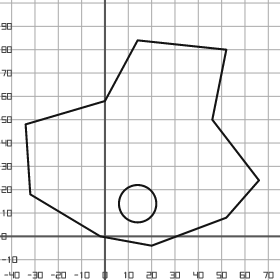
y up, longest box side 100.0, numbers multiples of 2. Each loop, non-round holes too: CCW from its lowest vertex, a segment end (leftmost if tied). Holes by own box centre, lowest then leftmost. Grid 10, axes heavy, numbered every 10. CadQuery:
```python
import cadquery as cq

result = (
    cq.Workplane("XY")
    .moveTo(20.0, -4.0)
    .lineTo(52.0, 8.0)
    .lineTo(66.0, 24.0)
    .lineTo(46.0, 50.0)
    .lineTo(52.0, 80.0)
    .lineTo(14.0, 84.0)
    .lineTo(0.0, 58.0)
    .lineTo(-34.0, 48.0)
    .lineTo(-32.0, 18.0)
    .lineTo(-2.0, 0.0)
    .close()
    .moveTo(14.0, 14.0)
    .circle(8.0)
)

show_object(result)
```